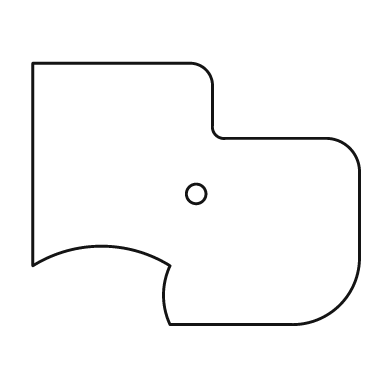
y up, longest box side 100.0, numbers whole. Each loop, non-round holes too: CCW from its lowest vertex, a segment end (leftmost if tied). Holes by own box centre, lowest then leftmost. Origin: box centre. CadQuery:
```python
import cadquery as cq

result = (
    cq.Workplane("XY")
    .moveTo(-8.0, -40.0)
    .lineTo(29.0, -40.0)
    .threePointArc((44.0, -34.0), (50.0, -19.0))
    .lineTo(50.0, 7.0)
    .threePointArc((47.0, 14.0), (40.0, 17.0))
    .lineTo(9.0, 17.0)
    .threePointArc((6.0, 18.0), (5.0, 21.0))
    .lineTo(5.0, 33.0)
    .threePointArc((3.0, 38.0), (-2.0, 40.0))
    .lineTo(-50.0, 40.0)
    .lineTo(-50.0, -22.0)
    .threePointArc((-29.0, -16.0), (-8.0, -22.0))
    .threePointArc((-10.0, -31.0), (-8.0, -40.0))
    .close()
    .moveTo(0.0, 0.0)
    .circle(3.0)
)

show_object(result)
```